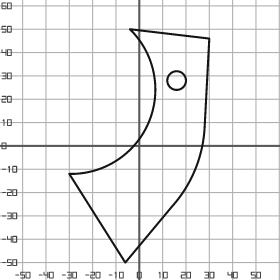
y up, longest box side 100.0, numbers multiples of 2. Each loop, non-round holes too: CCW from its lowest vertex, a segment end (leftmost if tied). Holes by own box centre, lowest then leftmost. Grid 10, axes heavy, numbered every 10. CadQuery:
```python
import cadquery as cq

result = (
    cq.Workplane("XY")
    .moveTo(-6.0, -50.0)
    .lineTo(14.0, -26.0)
    .threePointArc((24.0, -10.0), (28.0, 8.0))
    .lineTo(30.0, 46.0)
    .lineTo(-4.0, 50.0)
    .threePointArc((4.0, 10.0), (-30.0, -12.0))
    .close()
    .moveTo(16.0, 28.0)
    .circle(4.0)
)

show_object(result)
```